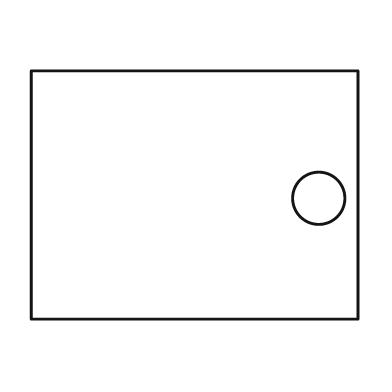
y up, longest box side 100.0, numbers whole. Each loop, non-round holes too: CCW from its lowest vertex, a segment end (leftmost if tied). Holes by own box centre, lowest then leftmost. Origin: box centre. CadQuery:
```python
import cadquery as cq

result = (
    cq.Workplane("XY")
    .moveTo(-50.0, -38.0)
    .lineTo(50.0, -38.0)
    .lineTo(50.0, 38.0)
    .lineTo(-50.0, 38.0)
    .close()
    .moveTo(38.0, -1.0)
    .circle(8.0)
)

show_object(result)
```